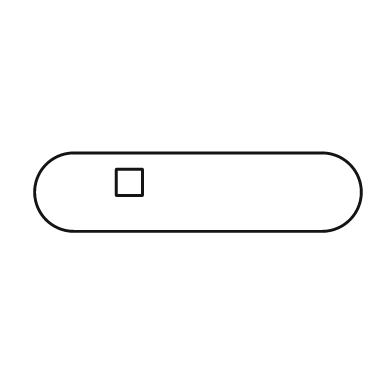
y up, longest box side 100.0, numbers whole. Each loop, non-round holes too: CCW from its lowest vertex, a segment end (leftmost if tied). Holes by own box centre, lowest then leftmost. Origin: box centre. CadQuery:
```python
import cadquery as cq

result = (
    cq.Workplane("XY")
    .moveTo(-38.0, -12.0)
    .lineTo(38.0, -12.0)
    .threePointArc((50.0, 0.0), (38.0, 12.0))
    .lineTo(-38.0, 12.0)
    .threePointArc((-50.0, 0.0), (-38.0, -12.0))
    .close()
    .moveTo(-25.0, -1.0)
    .lineTo(-17.0, -1.0)
    .lineTo(-17.0, 7.0)
    .lineTo(-25.0, 7.0)
    .close()
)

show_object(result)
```